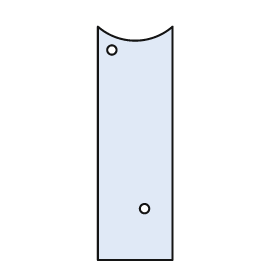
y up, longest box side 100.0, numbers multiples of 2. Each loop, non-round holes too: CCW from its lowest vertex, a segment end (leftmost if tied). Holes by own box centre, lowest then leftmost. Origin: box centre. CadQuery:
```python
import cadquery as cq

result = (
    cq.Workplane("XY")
    .moveTo(-16.0, -50.0)
    .lineTo(16.0, -50.0)
    .lineTo(16.0, 50.0)
    .threePointArc((0.0, 44.0), (-16.0, 50.0))
    .close()
    .moveTo(4.0, -28.0)
    .circle(2.0)
    .moveTo(-10.0, 40.0)
    .circle(2.0)
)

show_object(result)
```